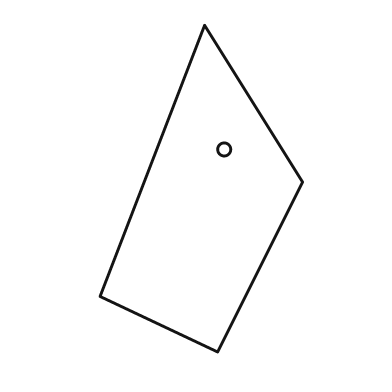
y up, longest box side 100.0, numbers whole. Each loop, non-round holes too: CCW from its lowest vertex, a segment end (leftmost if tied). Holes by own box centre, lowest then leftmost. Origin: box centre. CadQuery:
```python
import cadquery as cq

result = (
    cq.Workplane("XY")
    .moveTo(5.0, -50.0)
    .lineTo(31.0, 2.0)
    .lineTo(1.0, 50.0)
    .lineTo(-31.0, -33.0)
    .close()
    .moveTo(7.0, 12.0)
    .circle(2.0)
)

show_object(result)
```